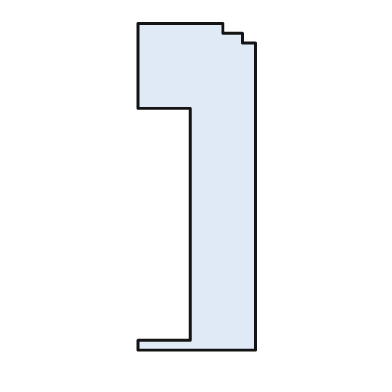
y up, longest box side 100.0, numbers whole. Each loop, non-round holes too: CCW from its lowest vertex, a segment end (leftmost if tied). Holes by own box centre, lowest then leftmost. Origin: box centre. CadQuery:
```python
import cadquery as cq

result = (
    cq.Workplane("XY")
    .moveTo(-18.0, -50.0)
    .lineTo(18.0, -50.0)
    .lineTo(18.0, 44.0)
    .lineTo(14.0, 44.0)
    .lineTo(14.0, 47.0)
    .lineTo(8.0, 47.0)
    .lineTo(8.0, 50.0)
    .lineTo(-18.0, 50.0)
    .lineTo(-18.0, 24.0)
    .lineTo(-2.0, 24.0)
    .lineTo(-2.0, -47.0)
    .lineTo(-18.0, -47.0)
    .close()
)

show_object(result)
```